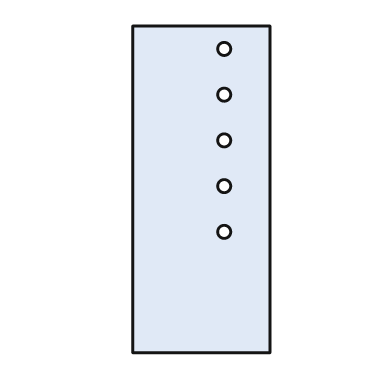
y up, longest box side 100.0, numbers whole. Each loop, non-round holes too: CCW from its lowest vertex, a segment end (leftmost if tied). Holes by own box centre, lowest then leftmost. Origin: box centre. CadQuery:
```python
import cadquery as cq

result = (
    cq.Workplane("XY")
    .moveTo(-21.0, -50.0)
    .lineTo(21.0, -50.0)
    .lineTo(21.0, 50.0)
    .lineTo(-21.0, 50.0)
    .close()
    .moveTo(7.0, -13.0)
    .circle(2.0)
    .moveTo(7.0, 1.0)
    .circle(2.0)
    .moveTo(7.0, 15.0)
    .circle(2.0)
    .moveTo(7.0, 29.0)
    .circle(2.0)
    .moveTo(7.0, 43.0)
    .circle(2.0)
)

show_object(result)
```